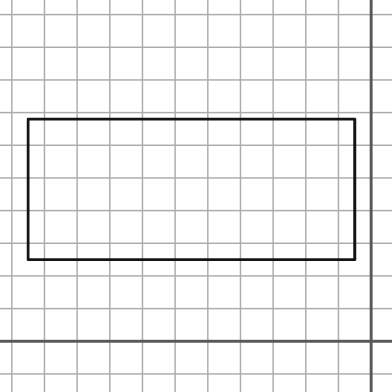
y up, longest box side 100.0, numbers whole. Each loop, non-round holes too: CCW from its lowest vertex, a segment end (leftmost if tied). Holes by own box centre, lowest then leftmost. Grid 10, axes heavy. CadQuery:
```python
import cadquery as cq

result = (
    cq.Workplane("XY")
    .moveTo(-105.0, 25.0)
    .lineTo(-5.0, 25.0)
    .lineTo(-5.0, 68.0)
    .lineTo(-105.0, 68.0)
    .close()
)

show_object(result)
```